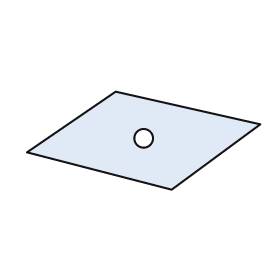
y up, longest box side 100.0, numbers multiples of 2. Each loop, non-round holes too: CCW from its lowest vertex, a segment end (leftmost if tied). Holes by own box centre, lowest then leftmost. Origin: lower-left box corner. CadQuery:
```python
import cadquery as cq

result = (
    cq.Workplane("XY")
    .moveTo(62.0, 0.0)
    .lineTo(100.0, 28.0)
    .lineTo(38.0, 42.0)
    .lineTo(0.0, 16.0)
    .close()
    .moveTo(50.0, 22.0)
    .circle(4.0)
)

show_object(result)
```